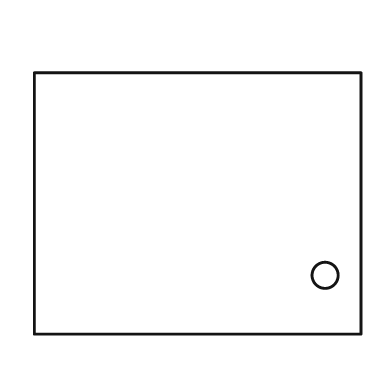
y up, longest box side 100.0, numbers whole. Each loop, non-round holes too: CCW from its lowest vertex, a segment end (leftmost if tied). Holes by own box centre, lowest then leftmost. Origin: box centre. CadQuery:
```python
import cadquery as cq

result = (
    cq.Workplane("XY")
    .moveTo(-50.0, -40.0)
    .lineTo(50.0, -40.0)
    .lineTo(50.0, 40.0)
    .lineTo(-50.0, 40.0)
    .close()
    .moveTo(39.0, -22.0)
    .circle(4.0)
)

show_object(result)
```